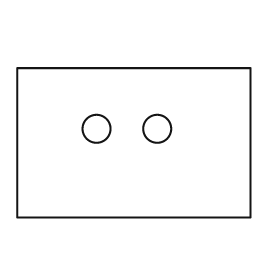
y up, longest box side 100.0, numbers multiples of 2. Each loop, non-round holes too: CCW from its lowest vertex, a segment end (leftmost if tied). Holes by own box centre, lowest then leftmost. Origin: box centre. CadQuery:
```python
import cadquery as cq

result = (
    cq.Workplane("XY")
    .moveTo(-50.0, -32.0)
    .lineTo(50.0, -32.0)
    .lineTo(50.0, 32.0)
    .lineTo(-50.0, 32.0)
    .close()
    .moveTo(-16.0, 6.0)
    .circle(6.0)
    .moveTo(10.0, 6.0)
    .circle(6.0)
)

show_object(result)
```